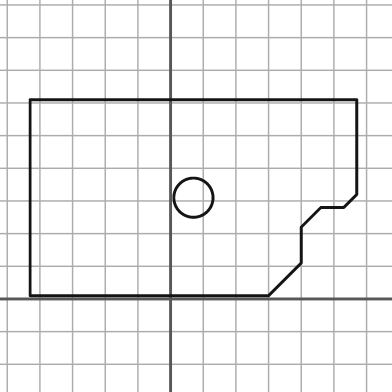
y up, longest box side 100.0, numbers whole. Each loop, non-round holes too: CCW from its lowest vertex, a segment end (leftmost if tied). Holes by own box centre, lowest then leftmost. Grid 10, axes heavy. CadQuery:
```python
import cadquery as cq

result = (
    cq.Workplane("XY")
    .moveTo(-43.0, 1.0)
    .lineTo(30.0, 1.0)
    .lineTo(40.0, 11.0)
    .lineTo(40.0, 22.0)
    .lineTo(46.0, 28.0)
    .lineTo(53.0, 28.0)
    .lineTo(57.0, 32.0)
    .lineTo(57.0, 61.0)
    .lineTo(-43.0, 61.0)
    .close()
    .moveTo(7.0, 31.0)
    .circle(6.0)
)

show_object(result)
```